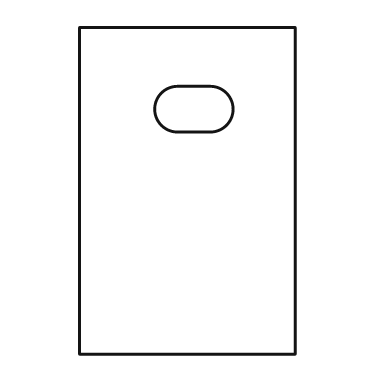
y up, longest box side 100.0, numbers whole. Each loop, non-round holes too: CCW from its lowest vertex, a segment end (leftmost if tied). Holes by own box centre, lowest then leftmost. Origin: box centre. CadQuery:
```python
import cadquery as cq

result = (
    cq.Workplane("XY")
    .moveTo(-33.0, -50.0)
    .lineTo(33.0, -50.0)
    .lineTo(33.0, 50.0)
    .lineTo(-33.0, 50.0)
    .close()
    .moveTo(-3.0, 18.0)
    .lineTo(7.0, 18.0)
    .threePointArc((14.0, 25.0), (7.0, 32.0))
    .lineTo(-3.0, 32.0)
    .threePointArc((-10.0, 25.0), (-3.0, 18.0))
    .close()
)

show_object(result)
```